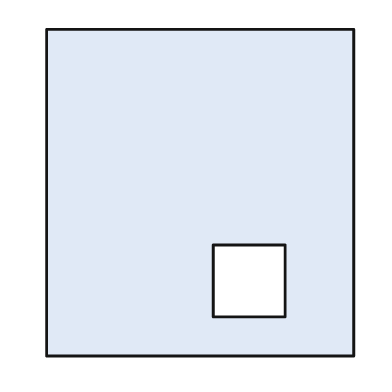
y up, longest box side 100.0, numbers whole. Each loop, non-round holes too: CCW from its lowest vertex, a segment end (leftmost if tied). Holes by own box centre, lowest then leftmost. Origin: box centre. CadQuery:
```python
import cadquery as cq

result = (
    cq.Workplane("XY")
    .moveTo(-47.0, -50.0)
    .lineTo(47.0, -50.0)
    .lineTo(47.0, 50.0)
    .lineTo(-47.0, 50.0)
    .close()
    .moveTo(4.0, -38.0)
    .lineTo(26.0, -38.0)
    .lineTo(26.0, -16.0)
    .lineTo(4.0, -16.0)
    .close()
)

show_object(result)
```